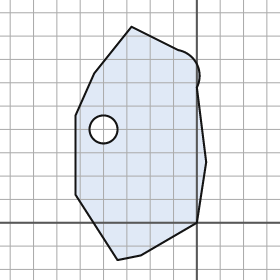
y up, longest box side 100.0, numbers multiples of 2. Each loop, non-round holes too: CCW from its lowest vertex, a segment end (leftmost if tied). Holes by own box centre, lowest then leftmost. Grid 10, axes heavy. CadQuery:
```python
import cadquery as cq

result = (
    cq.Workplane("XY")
    .moveTo(-34.0, -16.0)
    .lineTo(-24.0, -14.0)
    .lineTo(0.0, 0.0)
    .lineTo(4.0, 26.0)
    .lineTo(0.0, 58.0)
    .threePointArc((0.0, 68.0), (-8.0, 74.0))
    .lineTo(-28.0, 84.0)
    .lineTo(-44.0, 64.0)
    .lineTo(-52.0, 46.0)
    .lineTo(-52.0, 12.0)
    .close()
    .moveTo(-40.0, 40.0)
    .circle(6.0)
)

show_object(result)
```